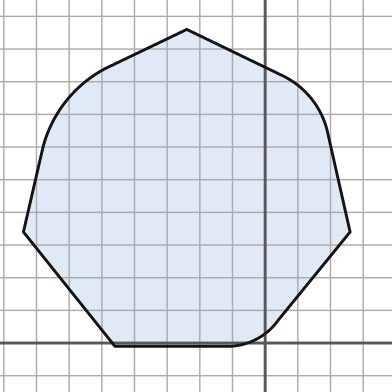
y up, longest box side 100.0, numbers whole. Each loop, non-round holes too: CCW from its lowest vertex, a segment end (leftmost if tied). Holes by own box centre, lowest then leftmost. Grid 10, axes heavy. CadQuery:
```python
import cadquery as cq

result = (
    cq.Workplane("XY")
    .moveTo(-46.0, -1.0)
    .lineTo(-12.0, -1.0)
    .threePointArc((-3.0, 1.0), (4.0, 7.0))
    .lineTo(26.0, 34.0)
    .lineTo(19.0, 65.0)
    .threePointArc((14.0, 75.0), (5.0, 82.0))
    .lineTo(-24.0, 96.0)
    .lineTo(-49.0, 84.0)
    .threePointArc((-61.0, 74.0), (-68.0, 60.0))
    .lineTo(-74.0, 34.0)
    .close()
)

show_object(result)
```